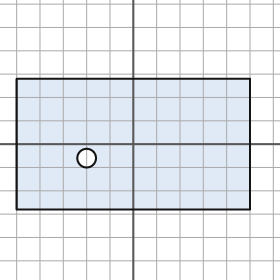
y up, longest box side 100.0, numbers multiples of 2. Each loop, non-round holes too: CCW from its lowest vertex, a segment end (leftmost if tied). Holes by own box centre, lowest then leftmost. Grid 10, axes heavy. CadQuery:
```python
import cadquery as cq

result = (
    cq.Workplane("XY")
    .moveTo(-50.0, -28.0)
    .lineTo(50.0, -28.0)
    .lineTo(50.0, 28.0)
    .lineTo(-50.0, 28.0)
    .close()
    .moveTo(-20.0, -6.0)
    .circle(4.0)
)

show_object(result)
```